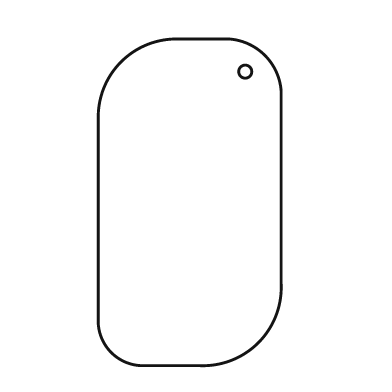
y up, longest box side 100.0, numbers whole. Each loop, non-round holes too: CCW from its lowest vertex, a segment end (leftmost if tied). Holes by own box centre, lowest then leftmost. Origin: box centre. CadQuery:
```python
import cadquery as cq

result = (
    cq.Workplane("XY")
    .moveTo(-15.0, -50.0)
    .lineTo(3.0, -50.0)
    .threePointArc((21.0, -43.0), (28.0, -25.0))
    .lineTo(28.0, 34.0)
    .threePointArc((23.0, 45.0), (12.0, 50.0))
    .lineTo(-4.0, 50.0)
    .threePointArc((-21.0, 43.0), (-28.0, 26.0))
    .lineTo(-28.0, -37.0)
    .threePointArc((-24.0, -46.0), (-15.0, -50.0))
    .close()
    .moveTo(17.0, 40.0)
    .circle(2.0)
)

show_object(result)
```